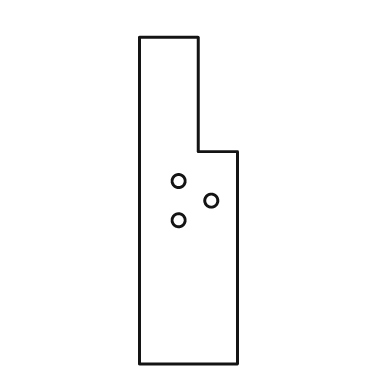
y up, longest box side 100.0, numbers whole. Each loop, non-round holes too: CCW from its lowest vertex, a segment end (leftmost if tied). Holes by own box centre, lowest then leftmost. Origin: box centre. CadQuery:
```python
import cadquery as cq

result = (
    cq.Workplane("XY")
    .moveTo(-15.0, -50.0)
    .lineTo(15.0, -50.0)
    .lineTo(15.0, 15.0)
    .lineTo(3.0, 15.0)
    .lineTo(3.0, 50.0)
    .lineTo(-15.0, 50.0)
    .close()
    .moveTo(-3.0, -6.0)
    .circle(2.0)
    .moveTo(7.0, 0.0)
    .circle(2.0)
    .moveTo(-3.0, 6.0)
    .circle(2.0)
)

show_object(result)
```